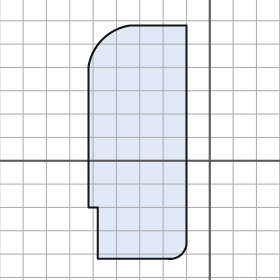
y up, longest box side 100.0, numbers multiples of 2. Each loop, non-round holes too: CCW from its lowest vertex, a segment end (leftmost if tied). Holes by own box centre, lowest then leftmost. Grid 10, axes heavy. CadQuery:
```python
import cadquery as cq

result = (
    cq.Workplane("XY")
    .moveTo(-48.0, -42.0)
    .lineTo(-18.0, -42.0)
    .threePointArc((-12.0, -40.0), (-10.0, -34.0))
    .lineTo(-10.0, 58.0)
    .lineTo(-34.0, 58.0)
    .threePointArc((-46.0, 52.0), (-52.0, 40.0))
    .lineTo(-52.0, -20.0)
    .lineTo(-48.0, -20.0)
    .close()
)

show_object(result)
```